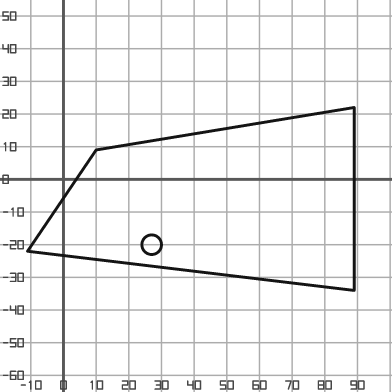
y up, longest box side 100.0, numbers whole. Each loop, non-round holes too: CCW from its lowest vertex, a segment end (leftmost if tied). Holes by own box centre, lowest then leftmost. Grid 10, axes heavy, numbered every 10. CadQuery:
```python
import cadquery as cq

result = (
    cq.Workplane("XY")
    .moveTo(89.0, -34.0)
    .lineTo(89.0, 22.0)
    .lineTo(10.0, 9.0)
    .lineTo(-11.0, -22.0)
    .close()
    .moveTo(27.0, -20.0)
    .circle(3.0)
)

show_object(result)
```